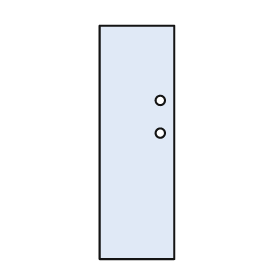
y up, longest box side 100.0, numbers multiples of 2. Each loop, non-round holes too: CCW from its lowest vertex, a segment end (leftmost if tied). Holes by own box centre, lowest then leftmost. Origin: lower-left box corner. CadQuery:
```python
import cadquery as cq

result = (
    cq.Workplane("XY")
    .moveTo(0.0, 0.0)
    .lineTo(32.0, 0.0)
    .lineTo(32.0, 100.0)
    .lineTo(0.0, 100.0)
    .close()
    .moveTo(26.0, 54.0)
    .circle(2.0)
    .moveTo(26.0, 68.0)
    .circle(2.0)
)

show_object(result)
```